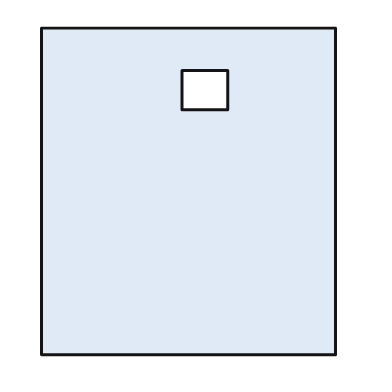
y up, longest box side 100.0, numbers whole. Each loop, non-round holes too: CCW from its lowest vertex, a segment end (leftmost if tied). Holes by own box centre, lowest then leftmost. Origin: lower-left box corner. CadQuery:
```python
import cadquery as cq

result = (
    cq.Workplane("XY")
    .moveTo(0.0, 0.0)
    .lineTo(90.0, 0.0)
    .lineTo(90.0, 100.0)
    .lineTo(0.0, 100.0)
    .close()
    .moveTo(43.0, 75.0)
    .lineTo(57.0, 75.0)
    .lineTo(57.0, 87.0)
    .lineTo(43.0, 87.0)
    .close()
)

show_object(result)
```